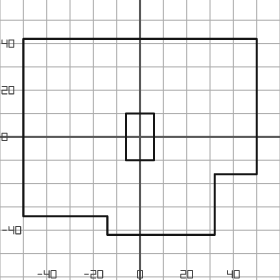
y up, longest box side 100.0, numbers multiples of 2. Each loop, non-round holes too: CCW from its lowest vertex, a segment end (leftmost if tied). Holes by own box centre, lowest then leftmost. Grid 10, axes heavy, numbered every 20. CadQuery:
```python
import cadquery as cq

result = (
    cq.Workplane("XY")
    .moveTo(-14.0, -42.0)
    .lineTo(32.0, -42.0)
    .lineTo(32.0, -16.0)
    .lineTo(50.0, -16.0)
    .lineTo(50.0, 42.0)
    .lineTo(-50.0, 42.0)
    .lineTo(-50.0, -34.0)
    .lineTo(-14.0, -34.0)
    .close()
    .moveTo(-6.0, -10.0)
    .lineTo(6.0, -10.0)
    .lineTo(6.0, 10.0)
    .lineTo(-6.0, 10.0)
    .close()
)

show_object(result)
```